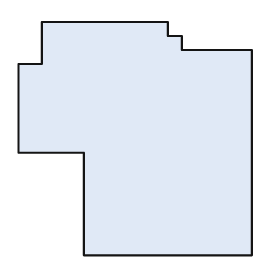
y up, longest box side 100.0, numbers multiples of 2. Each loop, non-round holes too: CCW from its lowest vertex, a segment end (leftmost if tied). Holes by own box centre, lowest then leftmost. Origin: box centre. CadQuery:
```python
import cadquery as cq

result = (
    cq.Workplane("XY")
    .moveTo(-22.0, -50.0)
    .lineTo(50.0, -50.0)
    .lineTo(50.0, 38.0)
    .lineTo(20.0, 38.0)
    .lineTo(20.0, 44.0)
    .lineTo(14.0, 44.0)
    .lineTo(14.0, 50.0)
    .lineTo(-40.0, 50.0)
    .lineTo(-40.0, 32.0)
    .lineTo(-50.0, 32.0)
    .lineTo(-50.0, -6.0)
    .lineTo(-22.0, -6.0)
    .close()
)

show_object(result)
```